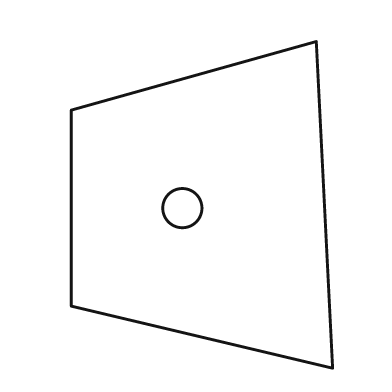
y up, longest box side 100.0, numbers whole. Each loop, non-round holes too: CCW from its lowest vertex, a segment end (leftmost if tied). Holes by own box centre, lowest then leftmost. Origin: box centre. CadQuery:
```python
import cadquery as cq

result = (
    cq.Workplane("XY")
    .moveTo(40.0, -50.0)
    .lineTo(35.0, 50.0)
    .lineTo(-40.0, 29.0)
    .lineTo(-40.0, -31.0)
    .close()
    .moveTo(-6.0, -1.0)
    .circle(6.0)
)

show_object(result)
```